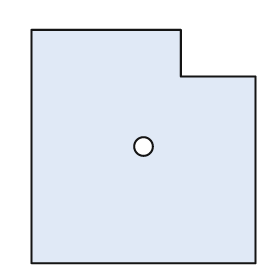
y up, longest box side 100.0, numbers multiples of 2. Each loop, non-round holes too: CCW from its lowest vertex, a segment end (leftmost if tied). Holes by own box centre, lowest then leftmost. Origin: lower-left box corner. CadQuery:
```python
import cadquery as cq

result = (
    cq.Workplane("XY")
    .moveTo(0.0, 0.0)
    .lineTo(96.0, 0.0)
    .lineTo(96.0, 80.0)
    .lineTo(64.0, 80.0)
    .lineTo(64.0, 100.0)
    .lineTo(0.0, 100.0)
    .close()
    .moveTo(48.0, 50.0)
    .circle(4.0)
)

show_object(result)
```